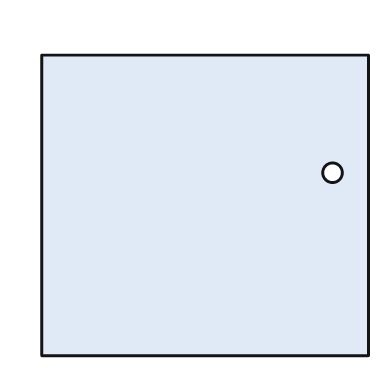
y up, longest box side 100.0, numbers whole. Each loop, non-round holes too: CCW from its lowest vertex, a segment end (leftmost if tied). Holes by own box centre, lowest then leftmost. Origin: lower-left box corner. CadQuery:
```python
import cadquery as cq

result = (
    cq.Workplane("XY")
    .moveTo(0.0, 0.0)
    .lineTo(100.0, 0.0)
    .lineTo(100.0, 92.0)
    .lineTo(0.0, 92.0)
    .close()
    .moveTo(89.0, 56.0)
    .circle(3.0)
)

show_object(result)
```